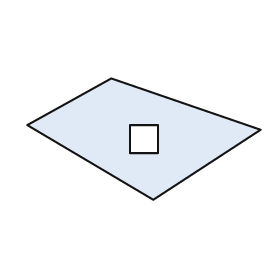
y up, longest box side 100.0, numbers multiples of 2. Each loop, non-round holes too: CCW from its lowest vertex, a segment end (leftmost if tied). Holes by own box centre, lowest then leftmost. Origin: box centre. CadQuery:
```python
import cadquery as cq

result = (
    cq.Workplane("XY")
    .moveTo(4.0, -26.0)
    .lineTo(50.0, 4.0)
    .lineTo(-14.0, 26.0)
    .lineTo(-50.0, 6.0)
    .close()
    .moveTo(-6.0, -6.0)
    .lineTo(6.0, -6.0)
    .lineTo(6.0, 6.0)
    .lineTo(-6.0, 6.0)
    .close()
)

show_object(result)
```